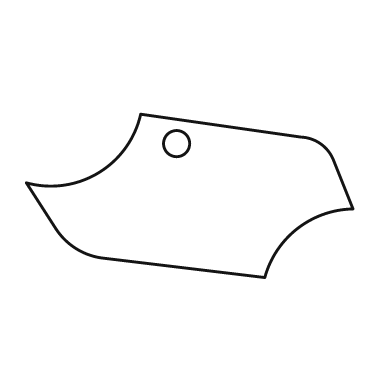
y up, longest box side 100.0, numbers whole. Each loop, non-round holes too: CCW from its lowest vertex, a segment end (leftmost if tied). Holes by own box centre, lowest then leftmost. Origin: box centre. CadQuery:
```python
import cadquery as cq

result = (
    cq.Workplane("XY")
    .moveTo(23.0, -25.0)
    .threePointArc((33.0, -10.0), (50.0, -4.0))
    .lineTo(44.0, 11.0)
    .threePointArc((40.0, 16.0), (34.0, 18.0))
    .lineTo(-15.0, 25.0)
    .threePointArc((-28.0, 7.0), (-50.0, 4.0))
    .lineTo(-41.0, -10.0)
    .threePointArc((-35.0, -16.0), (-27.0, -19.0))
    .close()
    .moveTo(-4.0, 16.0)
    .circle(4.0)
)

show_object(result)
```